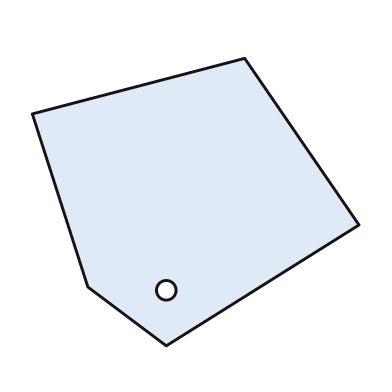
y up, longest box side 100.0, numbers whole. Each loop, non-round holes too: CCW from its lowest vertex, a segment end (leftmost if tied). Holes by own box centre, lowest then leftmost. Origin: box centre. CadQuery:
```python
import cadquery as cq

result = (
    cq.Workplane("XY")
    .moveTo(-9.0, -44.0)
    .lineTo(50.0, -7.0)
    .lineTo(15.0, 44.0)
    .lineTo(-50.0, 27.0)
    .lineTo(-33.0, -26.0)
    .close()
    .moveTo(-9.0, -27.0)
    .circle(3.0)
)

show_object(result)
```